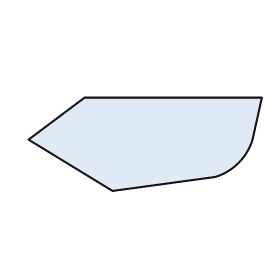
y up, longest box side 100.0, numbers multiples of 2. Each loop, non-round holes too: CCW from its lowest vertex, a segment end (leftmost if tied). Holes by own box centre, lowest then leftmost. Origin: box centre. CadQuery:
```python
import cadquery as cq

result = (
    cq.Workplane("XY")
    .moveTo(-14.0, -20.0)
    .lineTo(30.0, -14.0)
    .threePointArc((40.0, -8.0), (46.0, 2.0))
    .lineTo(50.0, 20.0)
    .lineTo(-26.0, 20.0)
    .lineTo(-50.0, 2.0)
    .close()
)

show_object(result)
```